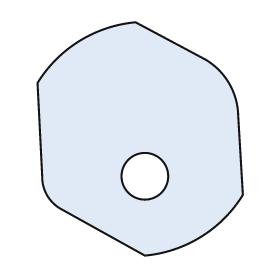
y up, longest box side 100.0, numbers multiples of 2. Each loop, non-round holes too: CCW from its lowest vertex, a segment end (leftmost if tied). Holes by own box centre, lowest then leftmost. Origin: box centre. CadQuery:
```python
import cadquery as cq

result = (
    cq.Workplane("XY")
    .moveTo(2.0, -50.0)
    .threePointArc((26.0, -42.0), (44.0, -24.0))
    .lineTo(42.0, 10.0)
    .threePointArc((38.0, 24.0), (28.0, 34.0))
    .lineTo(-2.0, 50.0)
    .threePointArc((-26.0, 42.0), (-44.0, 24.0))
    .lineTo(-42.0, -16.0)
    .threePointArc((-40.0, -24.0), (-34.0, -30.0))
    .close()
    .moveTo(2.0, -16.0)
    .circle(10.0)
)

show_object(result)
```